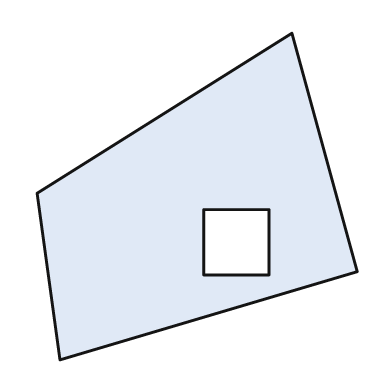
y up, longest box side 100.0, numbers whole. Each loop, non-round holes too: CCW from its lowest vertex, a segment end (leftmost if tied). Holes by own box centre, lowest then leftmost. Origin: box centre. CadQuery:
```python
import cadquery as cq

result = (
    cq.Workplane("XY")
    .moveTo(-42.0, -50.0)
    .lineTo(49.0, -23.0)
    .lineTo(29.0, 50.0)
    .lineTo(-49.0, 1.0)
    .close()
    .moveTo(2.0, -24.0)
    .lineTo(22.0, -24.0)
    .lineTo(22.0, -4.0)
    .lineTo(2.0, -4.0)
    .close()
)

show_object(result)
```